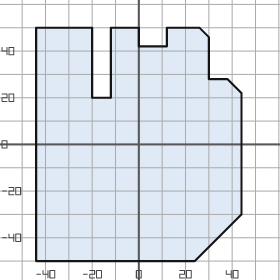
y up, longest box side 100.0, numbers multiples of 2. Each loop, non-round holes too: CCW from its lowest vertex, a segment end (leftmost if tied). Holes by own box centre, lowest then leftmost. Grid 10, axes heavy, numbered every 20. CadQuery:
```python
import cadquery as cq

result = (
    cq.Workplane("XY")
    .moveTo(-44.0, -50.0)
    .lineTo(24.0, -50.0)
    .lineTo(44.0, -30.0)
    .lineTo(44.0, 22.0)
    .lineTo(38.0, 28.0)
    .lineTo(30.0, 28.0)
    .lineTo(30.0, 46.0)
    .lineTo(26.0, 50.0)
    .lineTo(12.0, 50.0)
    .lineTo(12.0, 42.0)
    .lineTo(0.0, 42.0)
    .lineTo(0.0, 50.0)
    .lineTo(-12.0, 50.0)
    .lineTo(-12.0, 20.0)
    .lineTo(-20.0, 20.0)
    .lineTo(-20.0, 50.0)
    .lineTo(-44.0, 50.0)
    .close()
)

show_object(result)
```